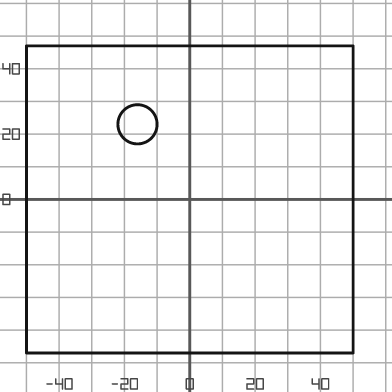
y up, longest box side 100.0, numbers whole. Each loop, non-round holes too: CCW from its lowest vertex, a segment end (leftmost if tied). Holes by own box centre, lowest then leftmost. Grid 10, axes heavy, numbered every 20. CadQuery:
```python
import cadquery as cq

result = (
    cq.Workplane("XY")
    .moveTo(-50.0, -47.0)
    .lineTo(50.0, -47.0)
    .lineTo(50.0, 47.0)
    .lineTo(-50.0, 47.0)
    .close()
    .moveTo(-16.0, 23.0)
    .circle(6.0)
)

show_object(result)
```